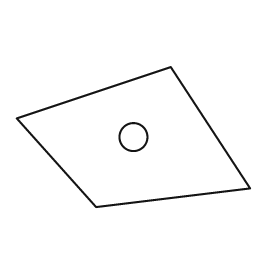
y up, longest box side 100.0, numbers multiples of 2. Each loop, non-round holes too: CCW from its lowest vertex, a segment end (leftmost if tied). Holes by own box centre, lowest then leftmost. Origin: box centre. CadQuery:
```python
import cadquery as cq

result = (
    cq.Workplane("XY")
    .moveTo(-16.0, -30.0)
    .lineTo(50.0, -22.0)
    .lineTo(16.0, 30.0)
    .lineTo(-50.0, 8.0)
    .close()
    .moveTo(0.0, 0.0)
    .circle(6.0)
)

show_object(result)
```